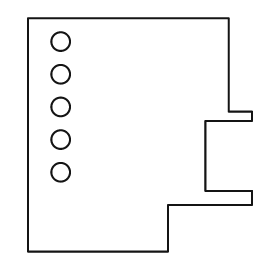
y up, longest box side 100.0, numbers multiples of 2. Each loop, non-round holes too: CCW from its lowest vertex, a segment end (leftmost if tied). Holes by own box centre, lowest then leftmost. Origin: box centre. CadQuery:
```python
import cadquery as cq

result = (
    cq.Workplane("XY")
    .moveTo(-48.0, -50.0)
    .lineTo(12.0, -50.0)
    .lineTo(12.0, -30.0)
    .lineTo(48.0, -30.0)
    .lineTo(48.0, -24.0)
    .lineTo(28.0, -24.0)
    .lineTo(28.0, 6.0)
    .lineTo(48.0, 6.0)
    .lineTo(48.0, 10.0)
    .lineTo(38.0, 10.0)
    .lineTo(38.0, 50.0)
    .lineTo(-48.0, 50.0)
    .close()
    .moveTo(-34.0, -16.0)
    .circle(4.0)
    .moveTo(-34.0, -2.0)
    .circle(4.0)
    .moveTo(-34.0, 12.0)
    .circle(4.0)
    .moveTo(-34.0, 26.0)
    .circle(4.0)
    .moveTo(-34.0, 40.0)
    .circle(4.0)
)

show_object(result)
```